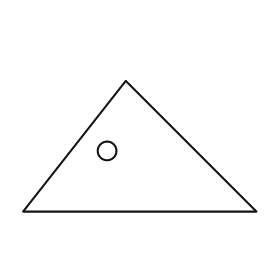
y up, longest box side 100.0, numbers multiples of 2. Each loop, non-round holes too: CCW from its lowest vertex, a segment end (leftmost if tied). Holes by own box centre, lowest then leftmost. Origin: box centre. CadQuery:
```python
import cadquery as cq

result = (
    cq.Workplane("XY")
    .moveTo(-50.0, -28.0)
    .lineTo(50.0, -28.0)
    .lineTo(-6.0, 28.0)
    .close()
    .moveTo(-14.0, -2.0)
    .circle(4.0)
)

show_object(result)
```